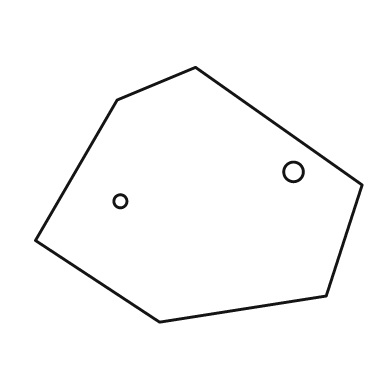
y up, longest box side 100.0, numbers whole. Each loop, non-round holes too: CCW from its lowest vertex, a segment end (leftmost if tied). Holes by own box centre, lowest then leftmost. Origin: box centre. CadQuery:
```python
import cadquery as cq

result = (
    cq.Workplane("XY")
    .moveTo(-12.0, -39.0)
    .lineTo(39.0, -31.0)
    .lineTo(50.0, 3.0)
    .lineTo(-1.0, 39.0)
    .lineTo(-25.0, 29.0)
    .lineTo(-50.0, -14.0)
    .close()
    .moveTo(-24.0, -2.0)
    .circle(2.0)
    .moveTo(29.0, 7.0)
    .circle(3.0)
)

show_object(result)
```